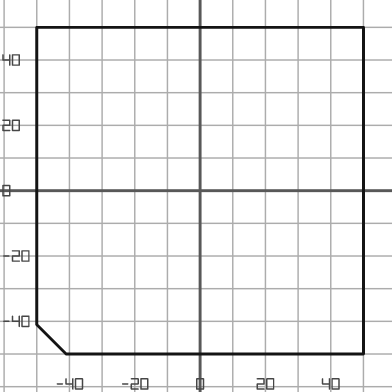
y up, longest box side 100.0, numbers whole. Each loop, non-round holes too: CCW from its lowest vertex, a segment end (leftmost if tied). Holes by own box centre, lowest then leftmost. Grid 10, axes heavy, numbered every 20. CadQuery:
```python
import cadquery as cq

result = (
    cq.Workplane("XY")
    .moveTo(-41.0, -50.0)
    .lineTo(50.0, -50.0)
    .lineTo(50.0, 50.0)
    .lineTo(-50.0, 50.0)
    .lineTo(-50.0, -41.0)
    .close()
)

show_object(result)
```